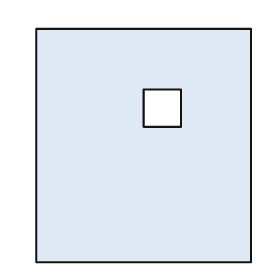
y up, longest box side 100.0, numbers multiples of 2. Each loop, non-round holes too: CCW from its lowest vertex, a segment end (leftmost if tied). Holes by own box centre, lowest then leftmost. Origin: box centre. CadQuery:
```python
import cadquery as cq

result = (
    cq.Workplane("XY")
    .moveTo(-46.0, -50.0)
    .lineTo(46.0, -50.0)
    .lineTo(46.0, 50.0)
    .lineTo(-46.0, 50.0)
    .close()
    .moveTo(0.0, 8.0)
    .lineTo(16.0, 8.0)
    .lineTo(16.0, 24.0)
    .lineTo(0.0, 24.0)
    .close()
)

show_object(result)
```